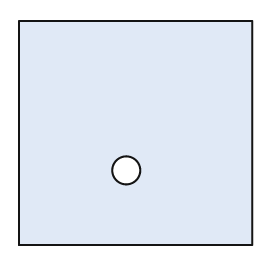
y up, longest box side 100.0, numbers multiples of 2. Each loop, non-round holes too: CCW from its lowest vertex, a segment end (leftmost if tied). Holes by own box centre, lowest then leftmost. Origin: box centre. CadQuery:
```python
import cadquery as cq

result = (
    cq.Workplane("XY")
    .moveTo(-50.0, -48.0)
    .lineTo(50.0, -48.0)
    .lineTo(50.0, 48.0)
    .lineTo(-50.0, 48.0)
    .close()
    .moveTo(-4.0, -16.0)
    .circle(6.0)
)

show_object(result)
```